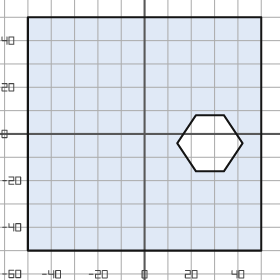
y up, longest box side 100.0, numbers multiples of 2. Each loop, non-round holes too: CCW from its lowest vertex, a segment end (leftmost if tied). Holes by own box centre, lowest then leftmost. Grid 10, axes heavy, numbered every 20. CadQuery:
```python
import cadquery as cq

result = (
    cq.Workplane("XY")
    .moveTo(-50.0, -50.0)
    .lineTo(50.0, -50.0)
    .lineTo(50.0, 50.0)
    .lineTo(-50.0, 50.0)
    .close()
    .moveTo(22.0, -16.0)
    .lineTo(34.0, -16.0)
    .lineTo(42.0, -4.0)
    .lineTo(34.0, 8.0)
    .lineTo(22.0, 8.0)
    .lineTo(14.0, -4.0)
    .close()
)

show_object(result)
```